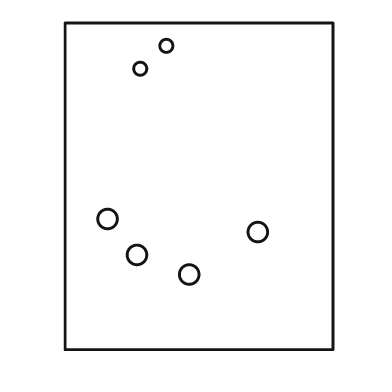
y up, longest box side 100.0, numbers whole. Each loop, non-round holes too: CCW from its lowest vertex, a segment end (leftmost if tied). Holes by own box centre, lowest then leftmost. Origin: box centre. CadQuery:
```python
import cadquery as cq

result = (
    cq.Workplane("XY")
    .moveTo(-41.0, -50.0)
    .lineTo(41.0, -50.0)
    .lineTo(41.0, 50.0)
    .lineTo(-41.0, 50.0)
    .close()
    .moveTo(-3.0, -27.0)
    .circle(3.0)
    .moveTo(-19.0, -21.0)
    .circle(3.0)
    .moveTo(18.0, -14.0)
    .circle(3.0)
    .moveTo(-28.0, -10.0)
    .circle(3.0)
    .moveTo(-18.0, 36.0)
    .circle(2.0)
    .moveTo(-10.0, 43.0)
    .circle(2.0)
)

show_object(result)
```